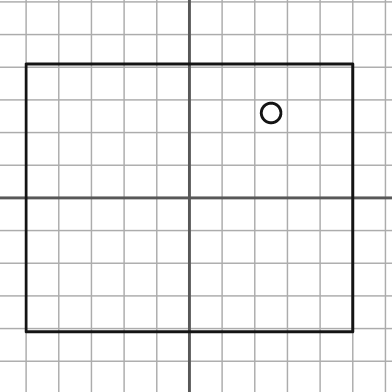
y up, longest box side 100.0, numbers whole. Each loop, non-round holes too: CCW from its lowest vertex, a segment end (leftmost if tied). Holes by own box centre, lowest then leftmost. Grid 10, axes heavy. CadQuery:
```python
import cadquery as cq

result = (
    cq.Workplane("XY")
    .moveTo(-50.0, -41.0)
    .lineTo(50.0, -41.0)
    .lineTo(50.0, 41.0)
    .lineTo(-50.0, 41.0)
    .close()
    .moveTo(25.0, 26.0)
    .circle(3.0)
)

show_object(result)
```